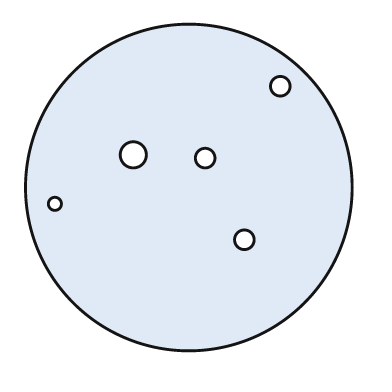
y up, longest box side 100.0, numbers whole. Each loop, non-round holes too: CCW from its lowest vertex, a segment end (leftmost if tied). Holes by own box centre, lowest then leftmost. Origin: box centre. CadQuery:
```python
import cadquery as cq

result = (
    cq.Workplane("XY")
    .moveTo(0.0, 0.0)
    .circle(50.0)
    .moveTo(17.0, -16.0)
    .circle(3.0)
    .moveTo(-41.0, -5.0)
    .circle(2.0)
    .moveTo(5.0, 9.0)
    .circle(3.0)
    .moveTo(-17.0, 10.0)
    .circle(4.0)
    .moveTo(28.0, 31.0)
    .circle(3.0)
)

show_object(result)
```